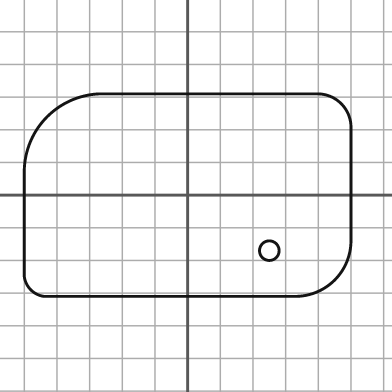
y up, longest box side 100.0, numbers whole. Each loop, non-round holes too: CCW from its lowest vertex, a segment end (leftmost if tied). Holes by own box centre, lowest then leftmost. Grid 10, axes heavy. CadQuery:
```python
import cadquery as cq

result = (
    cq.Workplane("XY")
    .moveTo(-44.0, -31.0)
    .lineTo(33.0, -31.0)
    .threePointArc((45.0, -26.0), (50.0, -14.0))
    .lineTo(50.0, 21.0)
    .threePointArc((47.0, 28.0), (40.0, 31.0))
    .lineTo(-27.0, 31.0)
    .threePointArc((-43.0, 24.0), (-50.0, 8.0))
    .lineTo(-50.0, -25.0)
    .threePointArc((-48.0, -29.0), (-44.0, -31.0))
    .close()
    .moveTo(25.0, -17.0)
    .circle(3.0)
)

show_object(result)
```